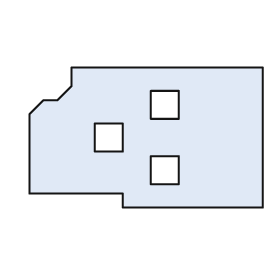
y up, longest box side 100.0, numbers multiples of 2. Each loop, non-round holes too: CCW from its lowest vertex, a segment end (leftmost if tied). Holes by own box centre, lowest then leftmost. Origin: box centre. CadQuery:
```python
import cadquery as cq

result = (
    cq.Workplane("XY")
    .moveTo(-10.0, -30.0)
    .lineTo(50.0, -30.0)
    .lineTo(50.0, 30.0)
    .lineTo(-32.0, 30.0)
    .lineTo(-32.0, 22.0)
    .lineTo(-38.0, 16.0)
    .lineTo(-44.0, 16.0)
    .lineTo(-50.0, 10.0)
    .lineTo(-50.0, -24.0)
    .lineTo(-10.0, -24.0)
    .close()
    .moveTo(2.0, -20.0)
    .lineTo(14.0, -20.0)
    .lineTo(14.0, -8.0)
    .lineTo(2.0, -8.0)
    .close()
    .moveTo(-22.0, -6.0)
    .lineTo(-10.0, -6.0)
    .lineTo(-10.0, 6.0)
    .lineTo(-22.0, 6.0)
    .close()
    .moveTo(2.0, 8.0)
    .lineTo(14.0, 8.0)
    .lineTo(14.0, 20.0)
    .lineTo(2.0, 20.0)
    .close()
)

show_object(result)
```